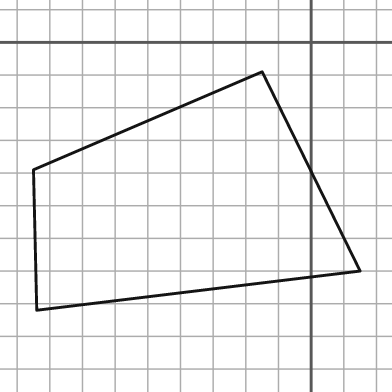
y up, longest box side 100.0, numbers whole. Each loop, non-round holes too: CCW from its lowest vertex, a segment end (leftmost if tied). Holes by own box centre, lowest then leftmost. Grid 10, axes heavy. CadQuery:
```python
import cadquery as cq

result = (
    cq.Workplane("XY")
    .moveTo(-84.0, -82.0)
    .lineTo(15.0, -70.0)
    .lineTo(-15.0, -9.0)
    .lineTo(-85.0, -39.0)
    .close()
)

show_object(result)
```